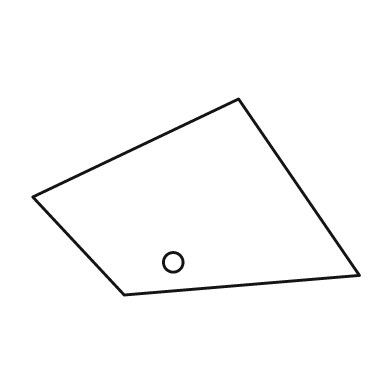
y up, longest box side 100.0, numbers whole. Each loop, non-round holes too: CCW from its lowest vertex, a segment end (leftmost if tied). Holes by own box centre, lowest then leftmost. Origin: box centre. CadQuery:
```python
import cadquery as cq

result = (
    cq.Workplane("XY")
    .moveTo(-22.0, -30.0)
    .lineTo(50.0, -24.0)
    .lineTo(13.0, 30.0)
    .lineTo(-50.0, 0.0)
    .close()
    .moveTo(-7.0, -20.0)
    .circle(3.0)
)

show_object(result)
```